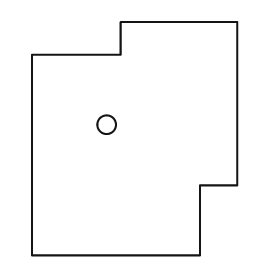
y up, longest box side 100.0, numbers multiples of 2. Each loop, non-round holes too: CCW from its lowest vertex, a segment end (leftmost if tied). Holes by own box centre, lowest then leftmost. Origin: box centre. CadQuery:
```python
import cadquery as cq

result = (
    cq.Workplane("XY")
    .moveTo(-44.0, -50.0)
    .lineTo(28.0, -50.0)
    .lineTo(28.0, -20.0)
    .lineTo(44.0, -20.0)
    .lineTo(44.0, 50.0)
    .lineTo(-6.0, 50.0)
    .lineTo(-6.0, 36.0)
    .lineTo(-44.0, 36.0)
    .close()
    .moveTo(-12.0, 6.0)
    .circle(4.0)
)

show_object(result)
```